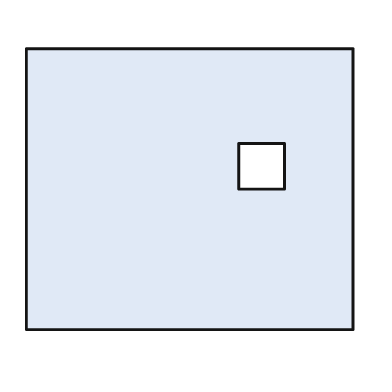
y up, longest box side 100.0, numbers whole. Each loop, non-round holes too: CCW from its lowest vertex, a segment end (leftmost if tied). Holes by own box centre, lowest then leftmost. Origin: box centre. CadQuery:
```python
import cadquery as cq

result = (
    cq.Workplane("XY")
    .moveTo(-50.0, -43.0)
    .lineTo(50.0, -43.0)
    .lineTo(50.0, 43.0)
    .lineTo(-50.0, 43.0)
    .close()
    .moveTo(15.0, 0.0)
    .lineTo(29.0, 0.0)
    .lineTo(29.0, 14.0)
    .lineTo(15.0, 14.0)
    .close()
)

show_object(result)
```